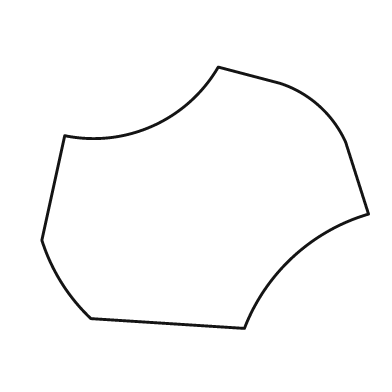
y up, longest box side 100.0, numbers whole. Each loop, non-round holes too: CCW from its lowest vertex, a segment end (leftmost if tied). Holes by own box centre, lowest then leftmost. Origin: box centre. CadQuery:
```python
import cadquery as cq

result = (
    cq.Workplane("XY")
    .moveTo(12.0, -40.0)
    .threePointArc((27.0, -18.0), (50.0, -5.0))
    .lineTo(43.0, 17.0)
    .threePointArc((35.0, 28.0), (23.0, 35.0))
    .lineTo(4.0, 40.0)
    .threePointArc((-16.0, 22.0), (-43.0, 19.0))
    .lineTo(-50.0, -13.0)
    .threePointArc((-44.0, -26.0), (-35.0, -37.0))
    .close()
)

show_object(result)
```